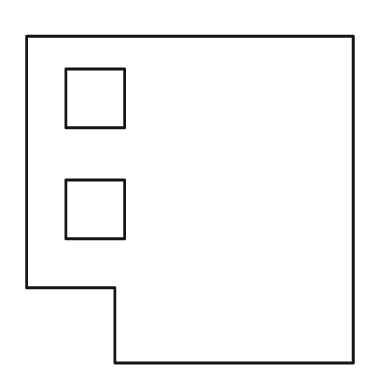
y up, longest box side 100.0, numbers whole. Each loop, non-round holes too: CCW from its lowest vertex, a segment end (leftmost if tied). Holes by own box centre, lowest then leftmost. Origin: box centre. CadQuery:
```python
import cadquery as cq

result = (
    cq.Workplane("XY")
    .moveTo(-23.0, -50.0)
    .lineTo(50.0, -50.0)
    .lineTo(50.0, 50.0)
    .lineTo(-50.0, 50.0)
    .lineTo(-50.0, -27.0)
    .lineTo(-23.0, -27.0)
    .close()
    .moveTo(-38.0, -12.0)
    .lineTo(-20.0, -12.0)
    .lineTo(-20.0, 6.0)
    .lineTo(-38.0, 6.0)
    .close()
    .moveTo(-38.0, 22.0)
    .lineTo(-20.0, 22.0)
    .lineTo(-20.0, 40.0)
    .lineTo(-38.0, 40.0)
    .close()
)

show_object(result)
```